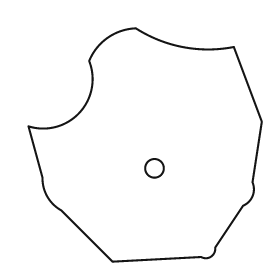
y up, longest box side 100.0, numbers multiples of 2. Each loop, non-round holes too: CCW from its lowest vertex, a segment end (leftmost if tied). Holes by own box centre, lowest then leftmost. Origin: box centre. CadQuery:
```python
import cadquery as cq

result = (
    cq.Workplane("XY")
    .moveTo(-14.0, -50.0)
    .lineTo(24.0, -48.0)
    .threePointArc((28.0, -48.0), (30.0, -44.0))
    .lineTo(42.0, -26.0)
    .threePointArc((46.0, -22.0), (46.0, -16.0))
    .lineTo(50.0, 10.0)
    .lineTo(38.0, 42.0)
    .threePointArc((16.0, 42.0), (-4.0, 50.0))
    .threePointArc((-16.0, 46.0), (-24.0, 36.0))
    .threePointArc((-28.0, 14.0), (-50.0, 8.0))
    .lineTo(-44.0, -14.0)
    .threePointArc((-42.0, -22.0), (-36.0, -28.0))
    .close()
    .moveTo(4.0, -10.0)
    .circle(4.0)
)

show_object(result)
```